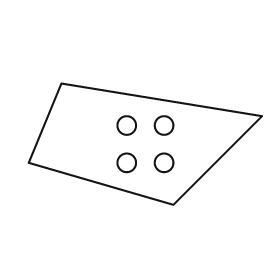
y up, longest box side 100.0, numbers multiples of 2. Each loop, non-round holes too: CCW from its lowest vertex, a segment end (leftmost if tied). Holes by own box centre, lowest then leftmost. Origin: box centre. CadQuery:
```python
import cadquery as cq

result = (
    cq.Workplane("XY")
    .moveTo(12.0, -26.0)
    .lineTo(50.0, 12.0)
    .lineTo(-36.0, 26.0)
    .lineTo(-50.0, -8.0)
    .close()
    .moveTo(-8.0, -8.0)
    .circle(4.0)
    .moveTo(8.0, -8.0)
    .circle(4.0)
    .moveTo(-8.0, 8.0)
    .circle(4.0)
    .moveTo(8.0, 8.0)
    .circle(4.0)
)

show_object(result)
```